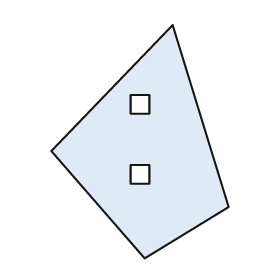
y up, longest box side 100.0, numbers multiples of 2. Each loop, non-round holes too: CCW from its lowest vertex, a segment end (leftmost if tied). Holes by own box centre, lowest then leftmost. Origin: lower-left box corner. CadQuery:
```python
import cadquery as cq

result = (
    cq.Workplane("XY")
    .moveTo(40.0, 0.0)
    .lineTo(76.0, 22.0)
    .lineTo(52.0, 100.0)
    .lineTo(0.0, 46.0)
    .close()
    .moveTo(34.0, 32.0)
    .lineTo(42.0, 32.0)
    .lineTo(42.0, 40.0)
    .lineTo(34.0, 40.0)
    .close()
    .moveTo(34.0, 62.0)
    .lineTo(42.0, 62.0)
    .lineTo(42.0, 70.0)
    .lineTo(34.0, 70.0)
    .close()
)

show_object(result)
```